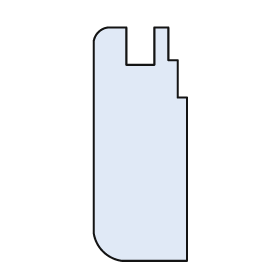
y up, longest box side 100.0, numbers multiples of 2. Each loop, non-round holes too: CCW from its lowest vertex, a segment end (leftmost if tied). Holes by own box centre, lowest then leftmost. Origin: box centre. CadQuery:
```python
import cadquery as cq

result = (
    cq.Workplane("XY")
    .moveTo(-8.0, -50.0)
    .lineTo(20.0, -50.0)
    .lineTo(20.0, 20.0)
    .lineTo(16.0, 20.0)
    .lineTo(16.0, 36.0)
    .lineTo(12.0, 36.0)
    .lineTo(12.0, 50.0)
    .lineTo(6.0, 50.0)
    .lineTo(6.0, 34.0)
    .lineTo(-6.0, 34.0)
    .lineTo(-6.0, 50.0)
    .lineTo(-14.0, 50.0)
    .threePointArc((-18.0, 48.0), (-20.0, 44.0))
    .lineTo(-20.0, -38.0)
    .threePointArc((-16.0, -46.0), (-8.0, -50.0))
    .close()
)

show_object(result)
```